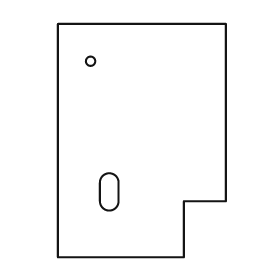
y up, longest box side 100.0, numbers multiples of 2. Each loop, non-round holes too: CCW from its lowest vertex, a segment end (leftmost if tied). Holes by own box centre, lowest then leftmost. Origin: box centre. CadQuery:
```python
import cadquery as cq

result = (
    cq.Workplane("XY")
    .moveTo(-36.0, -50.0)
    .lineTo(18.0, -50.0)
    .lineTo(18.0, -26.0)
    .lineTo(36.0, -26.0)
    .lineTo(36.0, 50.0)
    .lineTo(-36.0, 50.0)
    .close()
    .moveTo(-18.0, -26.0)
    .threePointArc((-14.0, -30.0), (-10.0, -26.0))
    .lineTo(-10.0, -18.0)
    .threePointArc((-14.0, -14.0), (-18.0, -18.0))
    .close()
    .moveTo(-22.0, 34.0)
    .circle(2.0)
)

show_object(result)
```